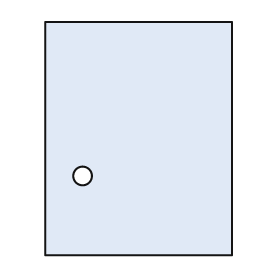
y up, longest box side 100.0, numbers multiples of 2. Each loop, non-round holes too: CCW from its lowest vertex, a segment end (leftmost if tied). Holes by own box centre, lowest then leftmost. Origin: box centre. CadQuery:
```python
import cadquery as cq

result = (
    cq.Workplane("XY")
    .moveTo(-40.0, -50.0)
    .lineTo(40.0, -50.0)
    .lineTo(40.0, 50.0)
    .lineTo(-40.0, 50.0)
    .close()
    .moveTo(-24.0, -16.0)
    .circle(4.0)
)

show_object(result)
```